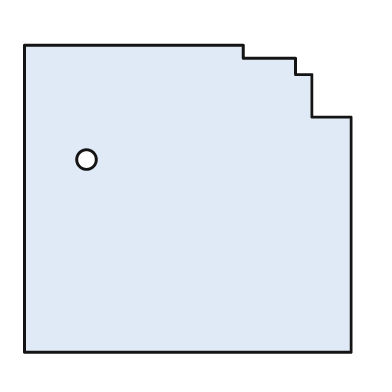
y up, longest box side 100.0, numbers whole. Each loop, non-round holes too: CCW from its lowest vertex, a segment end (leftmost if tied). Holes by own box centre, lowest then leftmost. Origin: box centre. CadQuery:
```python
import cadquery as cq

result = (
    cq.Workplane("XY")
    .moveTo(-50.0, -47.0)
    .lineTo(50.0, -47.0)
    .lineTo(50.0, 25.0)
    .lineTo(38.0, 25.0)
    .lineTo(38.0, 38.0)
    .lineTo(33.0, 38.0)
    .lineTo(33.0, 43.0)
    .lineTo(17.0, 43.0)
    .lineTo(17.0, 47.0)
    .lineTo(-50.0, 47.0)
    .close()
    .moveTo(-31.0, 12.0)
    .circle(3.0)
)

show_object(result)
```